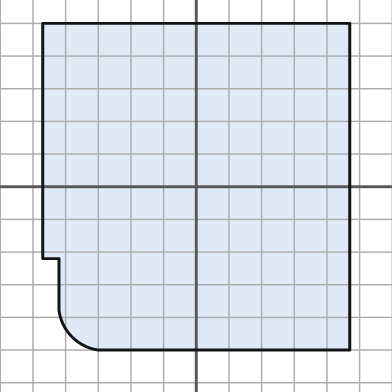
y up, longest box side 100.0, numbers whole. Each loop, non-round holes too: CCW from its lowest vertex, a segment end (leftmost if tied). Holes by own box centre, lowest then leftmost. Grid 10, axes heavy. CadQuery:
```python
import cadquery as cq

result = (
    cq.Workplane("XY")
    .moveTo(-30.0, -50.0)
    .lineTo(47.0, -50.0)
    .lineTo(47.0, 50.0)
    .lineTo(-47.0, 50.0)
    .lineTo(-47.0, -22.0)
    .lineTo(-42.0, -22.0)
    .lineTo(-42.0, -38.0)
    .threePointArc((-38.0, -46.0), (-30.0, -50.0))
    .close()
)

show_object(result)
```